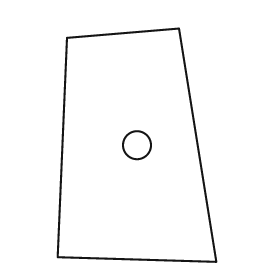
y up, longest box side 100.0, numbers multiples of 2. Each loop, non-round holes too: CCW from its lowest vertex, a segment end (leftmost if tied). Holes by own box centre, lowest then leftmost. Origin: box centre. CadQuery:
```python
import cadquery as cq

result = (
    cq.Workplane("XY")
    .moveTo(34.0, -50.0)
    .lineTo(18.0, 50.0)
    .lineTo(-30.0, 46.0)
    .lineTo(-34.0, -48.0)
    .close()
    .moveTo(0.0, 0.0)
    .circle(6.0)
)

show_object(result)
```